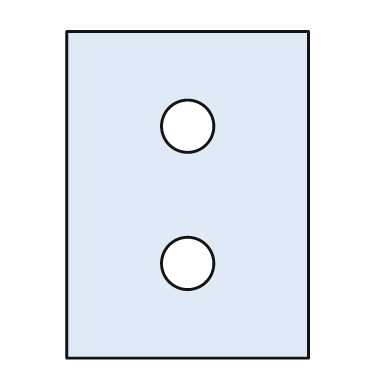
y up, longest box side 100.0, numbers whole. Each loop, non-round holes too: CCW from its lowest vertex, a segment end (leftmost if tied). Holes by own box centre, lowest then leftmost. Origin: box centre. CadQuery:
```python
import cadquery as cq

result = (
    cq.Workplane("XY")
    .moveTo(-37.0, -50.0)
    .lineTo(37.0, -50.0)
    .lineTo(37.0, 50.0)
    .lineTo(-37.0, 50.0)
    .close()
    .moveTo(0.0, -21.0)
    .circle(8.0)
    .moveTo(0.0, 21.0)
    .circle(8.0)
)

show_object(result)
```